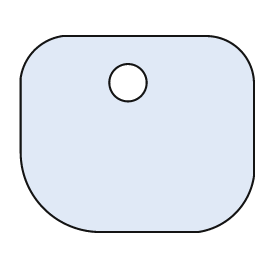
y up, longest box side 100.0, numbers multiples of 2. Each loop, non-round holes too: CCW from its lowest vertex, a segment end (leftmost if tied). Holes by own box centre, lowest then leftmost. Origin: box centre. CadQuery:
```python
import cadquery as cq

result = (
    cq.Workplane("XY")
    .moveTo(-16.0, -42.0)
    .lineTo(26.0, -42.0)
    .threePointArc((42.0, -34.0), (50.0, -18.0))
    .lineTo(50.0, 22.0)
    .threePointArc((44.0, 36.0), (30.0, 42.0))
    .lineTo(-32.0, 42.0)
    .threePointArc((-44.0, 36.0), (-50.0, 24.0))
    .lineTo(-50.0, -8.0)
    .threePointArc((-40.0, -32.0), (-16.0, -42.0))
    .close()
    .moveTo(-4.0, 22.0)
    .circle(8.0)
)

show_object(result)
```